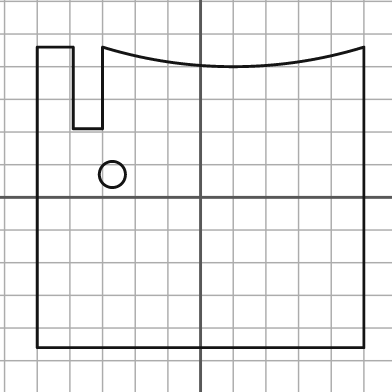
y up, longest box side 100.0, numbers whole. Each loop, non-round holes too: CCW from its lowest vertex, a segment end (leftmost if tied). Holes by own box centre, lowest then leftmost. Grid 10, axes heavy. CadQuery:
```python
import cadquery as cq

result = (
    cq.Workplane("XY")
    .moveTo(-50.0, -46.0)
    .lineTo(50.0, -46.0)
    .lineTo(50.0, 46.0)
    .threePointArc((10.0, 40.0), (-30.0, 46.0))
    .lineTo(-30.0, 21.0)
    .lineTo(-39.0, 21.0)
    .lineTo(-39.0, 46.0)
    .lineTo(-50.0, 46.0)
    .close()
    .moveTo(-27.0, 7.0)
    .circle(4.0)
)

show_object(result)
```